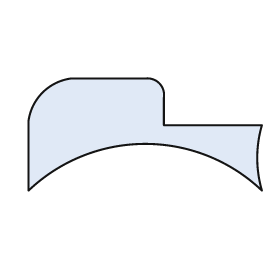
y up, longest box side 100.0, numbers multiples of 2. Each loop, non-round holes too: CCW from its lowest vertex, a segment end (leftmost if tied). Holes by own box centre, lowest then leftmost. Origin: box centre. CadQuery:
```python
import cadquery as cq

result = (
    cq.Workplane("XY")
    .moveTo(-50.0, -24.0)
    .threePointArc((0.0, -4.0), (50.0, -24.0))
    .threePointArc((48.0, -10.0), (50.0, 4.0))
    .lineTo(8.0, 4.0)
    .lineTo(8.0, 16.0)
    .threePointArc((6.0, 22.0), (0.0, 24.0))
    .lineTo(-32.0, 24.0)
    .threePointArc((-44.0, 18.0), (-50.0, 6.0))
    .close()
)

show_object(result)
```